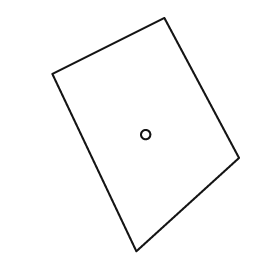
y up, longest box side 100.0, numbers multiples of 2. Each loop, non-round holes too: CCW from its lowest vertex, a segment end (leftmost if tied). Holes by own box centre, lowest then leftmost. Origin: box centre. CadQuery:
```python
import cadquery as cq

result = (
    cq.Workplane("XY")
    .moveTo(-4.0, -50.0)
    .lineTo(40.0, -10.0)
    .lineTo(8.0, 50.0)
    .lineTo(-40.0, 26.0)
    .close()
    .moveTo(0.0, 0.0)
    .circle(2.0)
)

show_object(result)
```